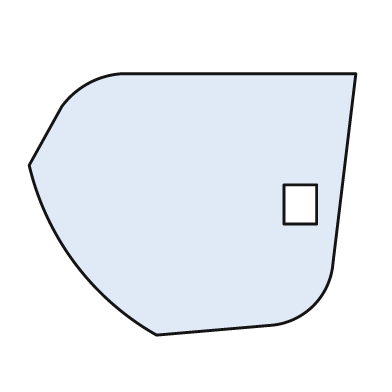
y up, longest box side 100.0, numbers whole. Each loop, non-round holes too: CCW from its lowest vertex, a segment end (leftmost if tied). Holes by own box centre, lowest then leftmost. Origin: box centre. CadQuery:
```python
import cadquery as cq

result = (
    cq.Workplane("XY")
    .moveTo(-11.0, -40.0)
    .lineTo(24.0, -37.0)
    .threePointArc((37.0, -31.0), (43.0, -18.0))
    .lineTo(50.0, 40.0)
    .lineTo(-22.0, 40.0)
    .threePointArc((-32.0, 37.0), (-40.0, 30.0))
    .lineTo(-50.0, 12.0)
    .threePointArc((-36.0, -18.0), (-11.0, -40.0))
    .close()
    .moveTo(28.0, -6.0)
    .lineTo(38.0, -6.0)
    .lineTo(38.0, 6.0)
    .lineTo(28.0, 6.0)
    .close()
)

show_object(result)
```